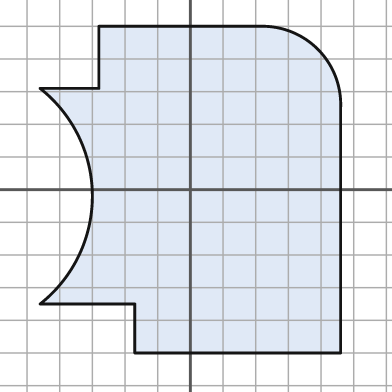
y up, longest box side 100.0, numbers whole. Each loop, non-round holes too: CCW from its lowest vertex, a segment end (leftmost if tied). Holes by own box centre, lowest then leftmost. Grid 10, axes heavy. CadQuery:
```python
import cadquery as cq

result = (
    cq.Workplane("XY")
    .moveTo(-17.0, -50.0)
    .lineTo(46.0, -50.0)
    .lineTo(46.0, 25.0)
    .threePointArc((39.0, 43.0), (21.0, 50.0))
    .lineTo(-28.0, 50.0)
    .lineTo(-28.0, 31.0)
    .lineTo(-46.0, 31.0)
    .threePointArc((-30.0, -2.0), (-46.0, -35.0))
    .lineTo(-17.0, -35.0)
    .close()
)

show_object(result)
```